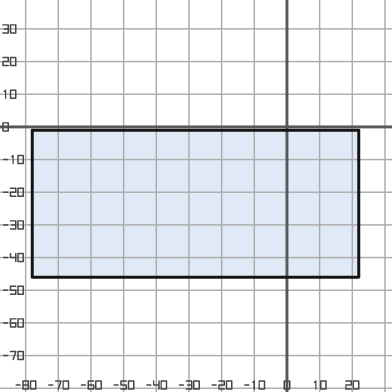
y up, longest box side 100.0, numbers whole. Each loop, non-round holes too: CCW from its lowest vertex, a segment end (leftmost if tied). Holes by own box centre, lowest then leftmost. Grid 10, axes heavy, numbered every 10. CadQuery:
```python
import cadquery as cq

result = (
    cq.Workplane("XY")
    .moveTo(-78.0, -46.0)
    .lineTo(22.0, -46.0)
    .lineTo(22.0, -1.0)
    .lineTo(-78.0, -1.0)
    .close()
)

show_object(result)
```